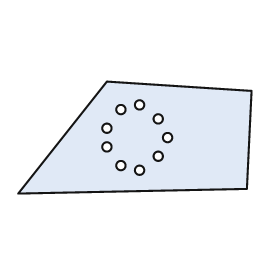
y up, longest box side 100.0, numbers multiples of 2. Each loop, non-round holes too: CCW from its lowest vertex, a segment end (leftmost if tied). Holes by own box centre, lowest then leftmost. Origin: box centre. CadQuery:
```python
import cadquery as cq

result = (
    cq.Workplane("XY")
    .moveTo(-50.0, -24.0)
    .lineTo(48.0, -22.0)
    .lineTo(50.0, 20.0)
    .lineTo(-12.0, 24.0)
    .close()
    .moveTo(2.0, -14.0)
    .circle(2.0)
    .moveTo(-6.0, -12.0)
    .circle(2.0)
    .moveTo(10.0, -8.0)
    .circle(2.0)
    .moveTo(-12.0, -4.0)
    .circle(2.0)
    .moveTo(14.0, 0.0)
    .circle(2.0)
    .moveTo(-12.0, 4.0)
    .circle(2.0)
    .moveTo(10.0, 8.0)
    .circle(2.0)
    .moveTo(-6.0, 12.0)
    .circle(2.0)
    .moveTo(2.0, 14.0)
    .circle(2.0)
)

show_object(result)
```